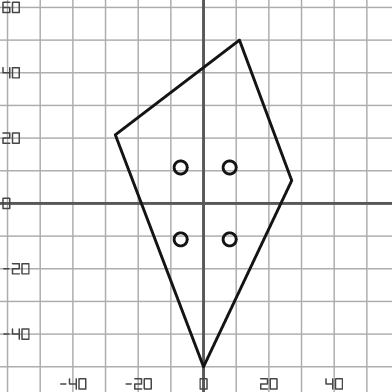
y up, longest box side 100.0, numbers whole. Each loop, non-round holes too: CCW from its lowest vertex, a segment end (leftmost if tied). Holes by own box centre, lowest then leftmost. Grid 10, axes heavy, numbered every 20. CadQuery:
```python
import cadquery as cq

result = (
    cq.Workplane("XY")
    .moveTo(0.0, -50.0)
    .lineTo(27.0, 7.0)
    .lineTo(11.0, 50.0)
    .lineTo(-27.0, 21.0)
    .close()
    .moveTo(-7.0, -11.0)
    .circle(2.0)
    .moveTo(8.0, -11.0)
    .circle(2.0)
    .moveTo(-7.0, 11.0)
    .circle(2.0)
    .moveTo(8.0, 11.0)
    .circle(2.0)
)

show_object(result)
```